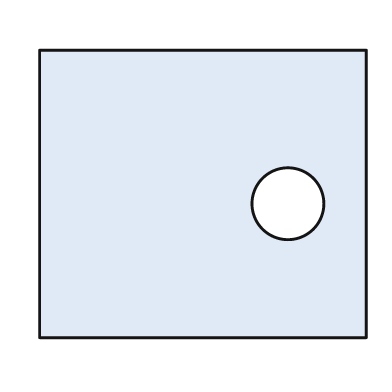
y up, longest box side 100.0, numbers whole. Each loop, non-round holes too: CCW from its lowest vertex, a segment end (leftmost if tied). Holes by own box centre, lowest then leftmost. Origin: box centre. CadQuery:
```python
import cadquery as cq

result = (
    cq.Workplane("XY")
    .moveTo(-50.0, -44.0)
    .lineTo(50.0, -44.0)
    .lineTo(50.0, 44.0)
    .lineTo(-50.0, 44.0)
    .close()
    .moveTo(26.0, -3.0)
    .circle(11.0)
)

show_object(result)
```